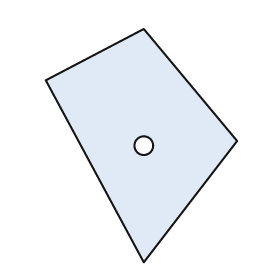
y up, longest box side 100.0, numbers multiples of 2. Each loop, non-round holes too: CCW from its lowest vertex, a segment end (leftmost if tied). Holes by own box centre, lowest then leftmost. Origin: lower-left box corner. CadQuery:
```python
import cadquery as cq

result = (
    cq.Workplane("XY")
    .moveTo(42.0, 0.0)
    .lineTo(82.0, 52.0)
    .lineTo(42.0, 100.0)
    .lineTo(0.0, 78.0)
    .close()
    .moveTo(42.0, 50.0)
    .circle(4.0)
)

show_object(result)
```